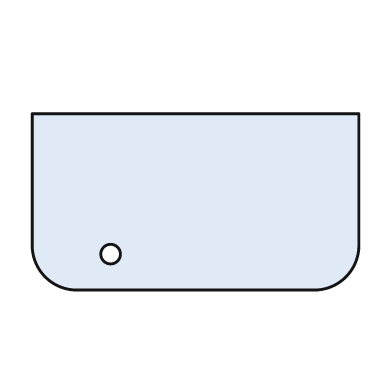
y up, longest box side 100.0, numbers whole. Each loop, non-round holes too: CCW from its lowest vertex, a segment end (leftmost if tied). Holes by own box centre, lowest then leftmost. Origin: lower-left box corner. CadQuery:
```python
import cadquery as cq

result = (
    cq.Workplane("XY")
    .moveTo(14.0, 0.0)
    .lineTo(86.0, 0.0)
    .threePointArc((96.0, 4.0), (100.0, 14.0))
    .lineTo(100.0, 54.0)
    .lineTo(0.0, 54.0)
    .lineTo(0.0, 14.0)
    .threePointArc((4.0, 4.0), (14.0, 0.0))
    .close()
    .moveTo(24.0, 11.0)
    .circle(3.0)
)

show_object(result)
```